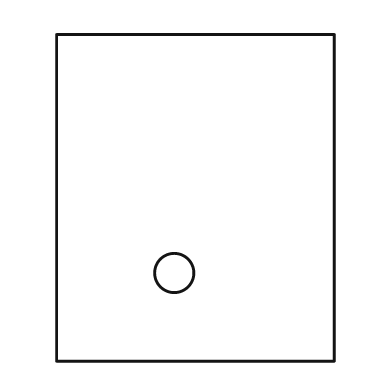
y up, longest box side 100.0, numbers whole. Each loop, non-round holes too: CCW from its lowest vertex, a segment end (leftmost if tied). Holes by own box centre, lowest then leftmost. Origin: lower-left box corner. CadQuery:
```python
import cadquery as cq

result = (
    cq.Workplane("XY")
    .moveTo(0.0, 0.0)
    .lineTo(85.0, 0.0)
    .lineTo(85.0, 100.0)
    .lineTo(0.0, 100.0)
    .close()
    .moveTo(36.0, 27.0)
    .circle(6.0)
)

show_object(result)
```